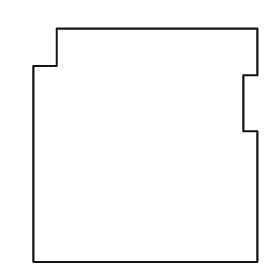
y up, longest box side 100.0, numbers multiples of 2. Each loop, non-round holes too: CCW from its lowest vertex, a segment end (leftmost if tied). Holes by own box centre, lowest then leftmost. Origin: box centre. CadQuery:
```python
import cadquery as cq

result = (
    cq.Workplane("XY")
    .moveTo(-48.0, -50.0)
    .lineTo(48.0, -50.0)
    .lineTo(48.0, 6.0)
    .lineTo(42.0, 6.0)
    .lineTo(42.0, 30.0)
    .lineTo(48.0, 30.0)
    .lineTo(48.0, 50.0)
    .lineTo(-38.0, 50.0)
    .lineTo(-38.0, 34.0)
    .lineTo(-48.0, 34.0)
    .close()
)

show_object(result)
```